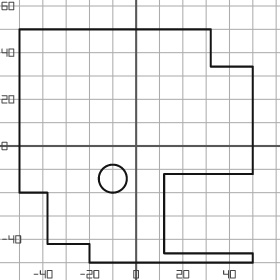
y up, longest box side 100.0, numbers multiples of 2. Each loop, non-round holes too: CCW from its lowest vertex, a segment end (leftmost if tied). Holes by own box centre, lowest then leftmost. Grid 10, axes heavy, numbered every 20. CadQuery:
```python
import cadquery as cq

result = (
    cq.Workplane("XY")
    .moveTo(-20.0, -50.0)
    .lineTo(50.0, -50.0)
    .lineTo(50.0, -46.0)
    .lineTo(12.0, -46.0)
    .lineTo(12.0, -12.0)
    .lineTo(50.0, -12.0)
    .lineTo(50.0, 34.0)
    .lineTo(32.0, 34.0)
    .lineTo(32.0, 50.0)
    .lineTo(-50.0, 50.0)
    .lineTo(-50.0, -20.0)
    .lineTo(-38.0, -20.0)
    .lineTo(-38.0, -42.0)
    .lineTo(-20.0, -42.0)
    .close()
    .moveTo(-10.0, -14.0)
    .circle(6.0)
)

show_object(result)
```